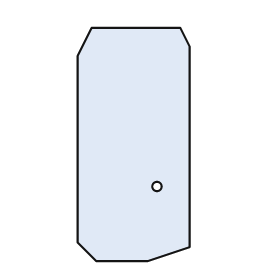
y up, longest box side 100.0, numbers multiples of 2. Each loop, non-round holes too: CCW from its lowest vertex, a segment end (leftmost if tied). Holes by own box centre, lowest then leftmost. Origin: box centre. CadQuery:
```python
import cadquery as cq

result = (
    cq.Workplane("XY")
    .moveTo(-16.0, -50.0)
    .lineTo(6.0, -50.0)
    .lineTo(24.0, -44.0)
    .lineTo(24.0, 42.0)
    .lineTo(20.0, 50.0)
    .lineTo(-18.0, 50.0)
    .lineTo(-24.0, 38.0)
    .lineTo(-24.0, -42.0)
    .close()
    .moveTo(10.0, -18.0)
    .circle(2.0)
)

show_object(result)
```